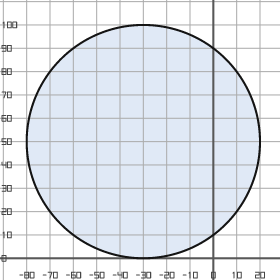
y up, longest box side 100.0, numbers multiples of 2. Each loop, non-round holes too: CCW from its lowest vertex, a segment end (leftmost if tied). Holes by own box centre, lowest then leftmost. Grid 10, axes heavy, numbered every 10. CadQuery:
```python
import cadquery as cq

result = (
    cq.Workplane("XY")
    .moveTo(-30.0, 50.0)
    .circle(50.0)
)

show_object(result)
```